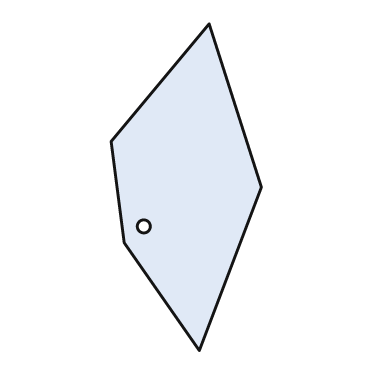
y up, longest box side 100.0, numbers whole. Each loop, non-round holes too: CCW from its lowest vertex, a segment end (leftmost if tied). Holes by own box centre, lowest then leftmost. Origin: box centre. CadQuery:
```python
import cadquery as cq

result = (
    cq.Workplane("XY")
    .moveTo(4.0, -50.0)
    .lineTo(23.0, 0.0)
    .lineTo(7.0, 50.0)
    .lineTo(-23.0, 14.0)
    .lineTo(-19.0, -17.0)
    .close()
    .moveTo(-13.0, -12.0)
    .circle(2.0)
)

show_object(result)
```